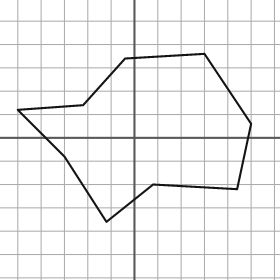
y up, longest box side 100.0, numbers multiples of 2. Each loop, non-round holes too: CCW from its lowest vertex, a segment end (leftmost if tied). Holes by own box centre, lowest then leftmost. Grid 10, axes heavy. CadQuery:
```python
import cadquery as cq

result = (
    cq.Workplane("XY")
    .moveTo(-12.0, -36.0)
    .lineTo(8.0, -20.0)
    .lineTo(44.0, -22.0)
    .lineTo(50.0, 6.0)
    .lineTo(30.0, 36.0)
    .lineTo(-4.0, 34.0)
    .lineTo(-22.0, 14.0)
    .lineTo(-50.0, 12.0)
    .lineTo(-30.0, -8.0)
    .close()
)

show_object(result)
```